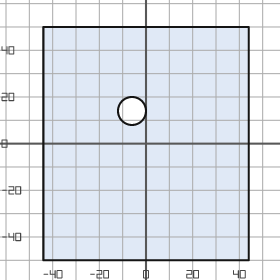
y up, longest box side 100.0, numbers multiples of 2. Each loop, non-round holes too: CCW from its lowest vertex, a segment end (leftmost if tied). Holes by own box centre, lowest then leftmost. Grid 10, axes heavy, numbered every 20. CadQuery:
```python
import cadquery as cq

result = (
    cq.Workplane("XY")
    .moveTo(-44.0, -50.0)
    .lineTo(44.0, -50.0)
    .lineTo(44.0, 50.0)
    .lineTo(-44.0, 50.0)
    .close()
    .moveTo(-6.0, 14.0)
    .circle(6.0)
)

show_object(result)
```